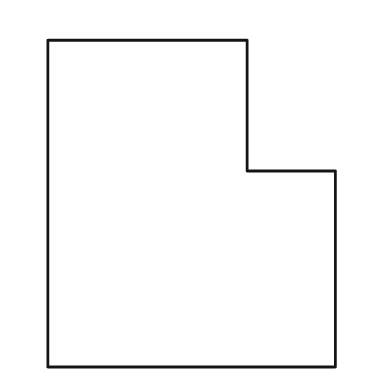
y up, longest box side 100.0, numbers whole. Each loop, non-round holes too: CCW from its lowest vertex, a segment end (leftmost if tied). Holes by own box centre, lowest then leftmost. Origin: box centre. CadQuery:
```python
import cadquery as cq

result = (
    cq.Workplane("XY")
    .moveTo(-44.0, -50.0)
    .lineTo(44.0, -50.0)
    .lineTo(44.0, 10.0)
    .lineTo(17.0, 10.0)
    .lineTo(17.0, 50.0)
    .lineTo(-44.0, 50.0)
    .close()
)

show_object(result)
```